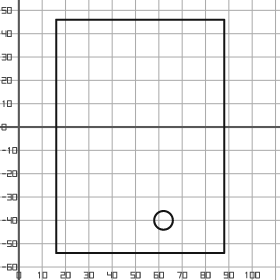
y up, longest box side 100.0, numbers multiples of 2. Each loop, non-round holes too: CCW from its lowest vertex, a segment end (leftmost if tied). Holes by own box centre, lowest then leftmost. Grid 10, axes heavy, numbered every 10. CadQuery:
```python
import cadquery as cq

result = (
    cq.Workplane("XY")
    .moveTo(16.0, -54.0)
    .lineTo(88.0, -54.0)
    .lineTo(88.0, 46.0)
    .lineTo(16.0, 46.0)
    .close()
    .moveTo(62.0, -40.0)
    .circle(4.0)
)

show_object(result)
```